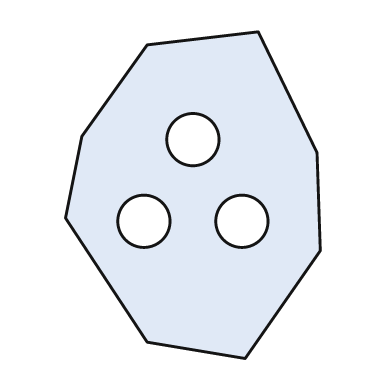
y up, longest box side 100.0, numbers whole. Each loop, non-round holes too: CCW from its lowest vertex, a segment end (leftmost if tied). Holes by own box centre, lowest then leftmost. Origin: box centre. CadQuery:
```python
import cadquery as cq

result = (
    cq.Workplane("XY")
    .moveTo(16.0, -50.0)
    .lineTo(39.0, -17.0)
    .lineTo(38.0, 13.0)
    .lineTo(20.0, 50.0)
    .lineTo(-14.0, 46.0)
    .lineTo(-34.0, 18.0)
    .lineTo(-39.0, -7.0)
    .lineTo(-14.0, -45.0)
    .close()
    .moveTo(-15.0, -8.0)
    .circle(8.0)
    .moveTo(15.0, -8.0)
    .circle(8.0)
    .moveTo(0.0, 17.0)
    .circle(8.0)
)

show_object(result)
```